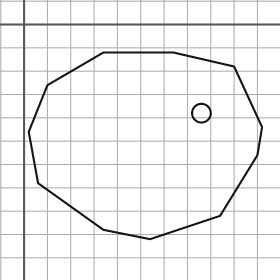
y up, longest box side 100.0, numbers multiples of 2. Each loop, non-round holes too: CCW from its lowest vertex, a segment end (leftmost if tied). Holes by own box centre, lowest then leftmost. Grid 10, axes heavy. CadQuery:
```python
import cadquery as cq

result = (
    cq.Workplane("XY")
    .moveTo(54.0, -92.0)
    .lineTo(84.0, -82.0)
    .lineTo(100.0, -56.0)
    .lineTo(102.0, -44.0)
    .lineTo(90.0, -18.0)
    .lineTo(64.0, -12.0)
    .lineTo(34.0, -12.0)
    .lineTo(10.0, -26.0)
    .lineTo(2.0, -46.0)
    .lineTo(6.0, -68.0)
    .lineTo(34.0, -88.0)
    .close()
    .moveTo(76.0, -38.0)
    .circle(4.0)
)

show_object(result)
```